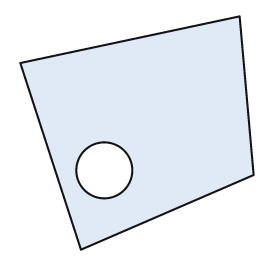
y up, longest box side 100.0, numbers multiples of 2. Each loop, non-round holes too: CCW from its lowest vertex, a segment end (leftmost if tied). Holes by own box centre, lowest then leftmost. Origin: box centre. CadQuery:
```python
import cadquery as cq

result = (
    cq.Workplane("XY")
    .moveTo(-24.0, -50.0)
    .lineTo(50.0, -18.0)
    .lineTo(44.0, 50.0)
    .lineTo(-50.0, 30.0)
    .close()
    .moveTo(-14.0, -16.0)
    .circle(12.0)
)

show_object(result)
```